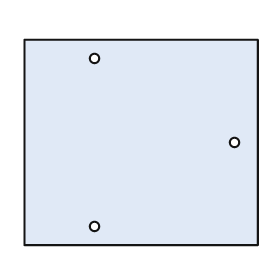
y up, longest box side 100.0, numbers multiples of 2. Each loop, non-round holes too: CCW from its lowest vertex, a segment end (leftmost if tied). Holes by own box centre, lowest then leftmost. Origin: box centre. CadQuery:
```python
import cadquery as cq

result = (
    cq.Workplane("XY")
    .moveTo(-50.0, -44.0)
    .lineTo(50.0, -44.0)
    .lineTo(50.0, 44.0)
    .lineTo(-50.0, 44.0)
    .close()
    .moveTo(-20.0, -36.0)
    .circle(2.0)
    .moveTo(40.0, 0.0)
    .circle(2.0)
    .moveTo(-20.0, 36.0)
    .circle(2.0)
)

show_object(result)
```